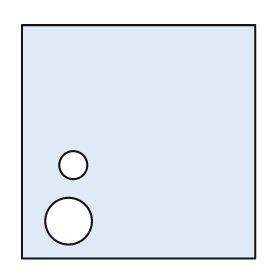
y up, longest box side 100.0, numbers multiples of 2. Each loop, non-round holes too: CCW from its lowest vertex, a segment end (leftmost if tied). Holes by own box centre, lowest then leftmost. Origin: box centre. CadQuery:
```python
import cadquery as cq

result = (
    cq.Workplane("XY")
    .moveTo(-50.0, -50.0)
    .lineTo(50.0, -50.0)
    .lineTo(50.0, 50.0)
    .lineTo(-50.0, 50.0)
    .close()
    .moveTo(-30.0, -34.0)
    .circle(10.0)
    .moveTo(-28.0, -10.0)
    .circle(6.0)
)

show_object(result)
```